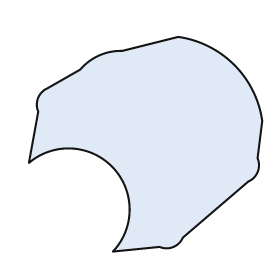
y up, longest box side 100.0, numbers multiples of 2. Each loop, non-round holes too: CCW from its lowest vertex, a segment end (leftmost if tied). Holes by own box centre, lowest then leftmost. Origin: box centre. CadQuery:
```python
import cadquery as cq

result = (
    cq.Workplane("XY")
    .moveTo(-14.0, -46.0)
    .lineTo(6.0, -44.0)
    .threePointArc((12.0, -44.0), (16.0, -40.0))
    .lineTo(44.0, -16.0)
    .threePointArc((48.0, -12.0), (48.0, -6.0))
    .lineTo(50.0, 10.0)
    .threePointArc((38.0, 34.0), (14.0, 46.0))
    .lineTo(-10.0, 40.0)
    .threePointArc((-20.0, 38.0), (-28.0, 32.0))
    .lineTo(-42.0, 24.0)
    .threePointArc((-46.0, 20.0), (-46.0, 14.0))
    .lineTo(-50.0, -8.0)
    .threePointArc((-14.0, -10.0), (-14.0, -46.0))
    .close()
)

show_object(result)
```